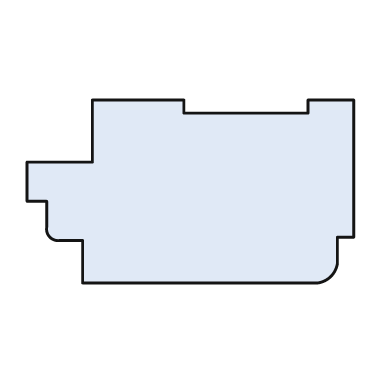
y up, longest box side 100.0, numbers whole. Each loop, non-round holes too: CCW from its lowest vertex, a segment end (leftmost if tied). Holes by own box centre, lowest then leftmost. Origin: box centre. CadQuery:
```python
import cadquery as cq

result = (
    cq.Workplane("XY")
    .moveTo(-33.0, -28.0)
    .lineTo(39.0, -28.0)
    .threePointArc((43.0, -26.0), (45.0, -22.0))
    .lineTo(45.0, -14.0)
    .lineTo(50.0, -14.0)
    .lineTo(50.0, 28.0)
    .lineTo(36.0, 28.0)
    .lineTo(36.0, 24.0)
    .lineTo(-2.0, 24.0)
    .lineTo(-2.0, 28.0)
    .lineTo(-30.0, 28.0)
    .lineTo(-30.0, 9.0)
    .lineTo(-50.0, 9.0)
    .lineTo(-50.0, -3.0)
    .lineTo(-44.0, -3.0)
    .lineTo(-44.0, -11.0)
    .threePointArc((-43.0, -14.0), (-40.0, -15.0))
    .lineTo(-33.0, -15.0)
    .close()
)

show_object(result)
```